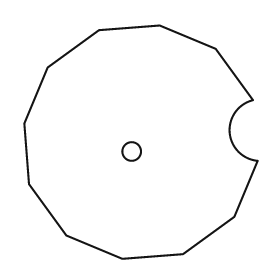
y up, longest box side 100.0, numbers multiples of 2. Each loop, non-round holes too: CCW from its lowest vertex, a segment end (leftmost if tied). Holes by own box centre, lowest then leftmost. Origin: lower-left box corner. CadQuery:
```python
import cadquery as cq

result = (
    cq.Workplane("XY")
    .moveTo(42.0, 0.0)
    .lineTo(68.0, 2.0)
    .lineTo(90.0, 18.0)
    .lineTo(100.0, 42.0)
    .threePointArc((88.0, 54.0), (98.0, 68.0))
    .lineTo(82.0, 90.0)
    .lineTo(58.0, 100.0)
    .lineTo(32.0, 98.0)
    .lineTo(10.0, 82.0)
    .lineTo(0.0, 58.0)
    .lineTo(2.0, 32.0)
    .lineTo(18.0, 10.0)
    .close()
    .moveTo(46.0, 46.0)
    .circle(4.0)
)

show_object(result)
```